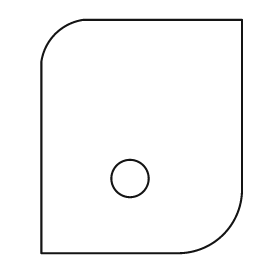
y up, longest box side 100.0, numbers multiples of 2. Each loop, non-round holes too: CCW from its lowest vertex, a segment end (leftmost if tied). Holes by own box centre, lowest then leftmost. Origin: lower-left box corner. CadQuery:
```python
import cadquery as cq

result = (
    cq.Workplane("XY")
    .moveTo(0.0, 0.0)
    .lineTo(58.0, 0.0)
    .threePointArc((78.0, 8.0), (86.0, 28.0))
    .lineTo(86.0, 100.0)
    .lineTo(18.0, 100.0)
    .threePointArc((6.0, 94.0), (0.0, 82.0))
    .close()
    .moveTo(38.0, 32.0)
    .circle(8.0)
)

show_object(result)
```